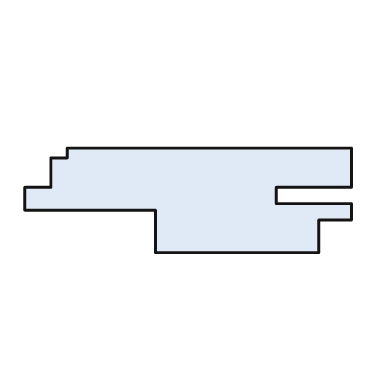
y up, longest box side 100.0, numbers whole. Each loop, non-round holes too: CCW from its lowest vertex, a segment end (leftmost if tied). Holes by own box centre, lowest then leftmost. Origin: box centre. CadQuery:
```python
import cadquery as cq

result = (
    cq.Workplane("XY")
    .moveTo(-10.0, -16.0)
    .lineTo(40.0, -16.0)
    .lineTo(40.0, -6.0)
    .lineTo(50.0, -6.0)
    .lineTo(50.0, -1.0)
    .lineTo(27.0, -1.0)
    .lineTo(27.0, 4.0)
    .lineTo(50.0, 4.0)
    .lineTo(50.0, 16.0)
    .lineTo(-37.0, 16.0)
    .lineTo(-37.0, 13.0)
    .lineTo(-42.0, 13.0)
    .lineTo(-42.0, 4.0)
    .lineTo(-50.0, 4.0)
    .lineTo(-50.0, -3.0)
    .lineTo(-10.0, -3.0)
    .close()
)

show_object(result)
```